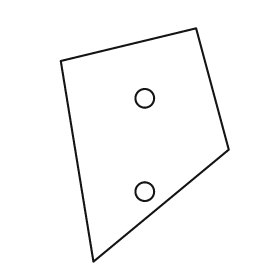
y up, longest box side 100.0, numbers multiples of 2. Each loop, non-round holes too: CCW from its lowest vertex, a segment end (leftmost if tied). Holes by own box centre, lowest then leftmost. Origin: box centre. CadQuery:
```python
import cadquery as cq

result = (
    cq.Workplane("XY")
    .moveTo(-22.0, -50.0)
    .lineTo(36.0, -2.0)
    .lineTo(22.0, 50.0)
    .lineTo(-36.0, 36.0)
    .close()
    .moveTo(0.0, -20.0)
    .circle(4.0)
    .moveTo(0.0, 20.0)
    .circle(4.0)
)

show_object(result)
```